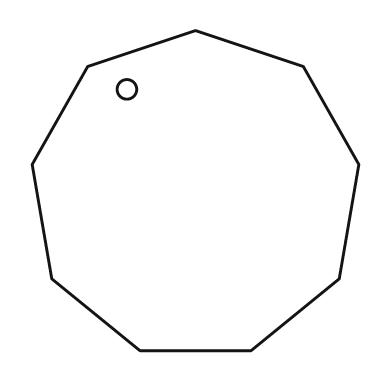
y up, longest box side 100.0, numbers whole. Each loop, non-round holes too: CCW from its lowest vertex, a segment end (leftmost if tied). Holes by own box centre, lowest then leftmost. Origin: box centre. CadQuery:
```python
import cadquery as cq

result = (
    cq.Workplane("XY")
    .moveTo(-17.0, -49.0)
    .lineTo(17.0, -49.0)
    .lineTo(44.0, -27.0)
    .lineTo(50.0, 8.0)
    .lineTo(33.0, 38.0)
    .lineTo(0.0, 49.0)
    .lineTo(-33.0, 38.0)
    .lineTo(-50.0, 8.0)
    .lineTo(-44.0, -27.0)
    .close()
    .moveTo(-21.0, 31.0)
    .circle(3.0)
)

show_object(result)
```